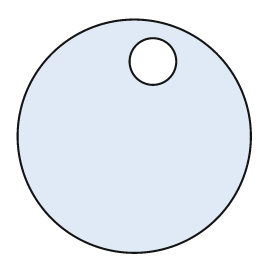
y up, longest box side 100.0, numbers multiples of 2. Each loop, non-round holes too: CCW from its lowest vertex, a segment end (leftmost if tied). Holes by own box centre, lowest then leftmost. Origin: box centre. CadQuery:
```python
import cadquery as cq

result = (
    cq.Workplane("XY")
    .moveTo(0.0, 0.0)
    .circle(50.0)
    .moveTo(8.0, 32.0)
    .circle(10.0)
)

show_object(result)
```